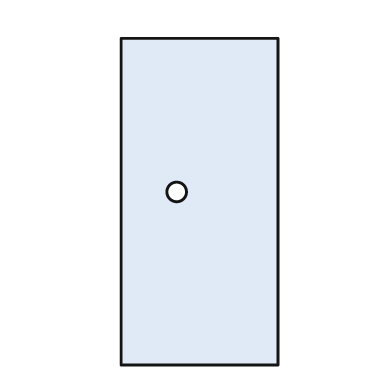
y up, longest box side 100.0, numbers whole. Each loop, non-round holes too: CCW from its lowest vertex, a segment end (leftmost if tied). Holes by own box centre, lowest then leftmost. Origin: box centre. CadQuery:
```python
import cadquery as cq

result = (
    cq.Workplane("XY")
    .moveTo(-24.0, -50.0)
    .lineTo(24.0, -50.0)
    .lineTo(24.0, 50.0)
    .lineTo(-24.0, 50.0)
    .close()
    .moveTo(-7.0, 3.0)
    .circle(3.0)
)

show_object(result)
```